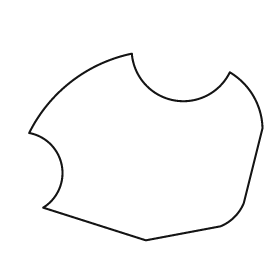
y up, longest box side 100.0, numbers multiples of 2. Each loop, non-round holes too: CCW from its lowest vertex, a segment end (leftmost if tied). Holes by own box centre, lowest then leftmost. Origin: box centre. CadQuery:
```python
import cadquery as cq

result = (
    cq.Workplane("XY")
    .moveTo(0.0, -40.0)
    .lineTo(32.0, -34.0)
    .threePointArc((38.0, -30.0), (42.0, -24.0))
    .lineTo(50.0, 8.0)
    .threePointArc((46.0, 22.0), (36.0, 32.0))
    .threePointArc((12.0, 20.0), (-6.0, 40.0))
    .threePointArc((-32.0, 28.0), (-50.0, 6.0))
    .threePointArc((-36.0, -8.0), (-44.0, -26.0))
    .close()
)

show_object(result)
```